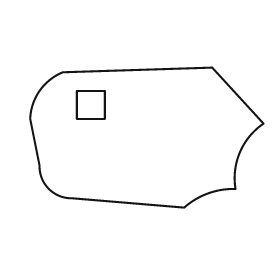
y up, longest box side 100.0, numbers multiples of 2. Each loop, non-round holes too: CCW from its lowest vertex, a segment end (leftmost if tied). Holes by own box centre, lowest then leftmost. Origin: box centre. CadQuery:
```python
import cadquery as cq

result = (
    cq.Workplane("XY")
    .moveTo(16.0, -30.0)
    .threePointArc((26.0, -24.0), (38.0, -22.0))
    .threePointArc((40.0, -6.0), (50.0, 6.0))
    .lineTo(28.0, 30.0)
    .lineTo(-36.0, 28.0)
    .threePointArc((-46.0, 20.0), (-50.0, 8.0))
    .lineTo(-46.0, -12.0)
    .threePointArc((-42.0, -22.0), (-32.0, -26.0))
    .close()
    .moveTo(-30.0, 8.0)
    .lineTo(-18.0, 8.0)
    .lineTo(-18.0, 20.0)
    .lineTo(-30.0, 20.0)
    .close()
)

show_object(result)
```